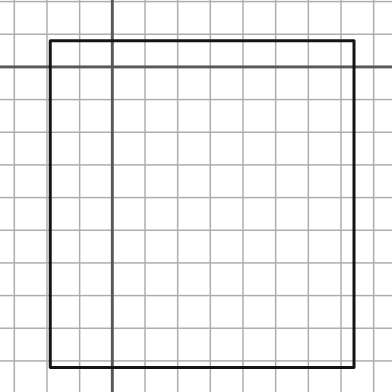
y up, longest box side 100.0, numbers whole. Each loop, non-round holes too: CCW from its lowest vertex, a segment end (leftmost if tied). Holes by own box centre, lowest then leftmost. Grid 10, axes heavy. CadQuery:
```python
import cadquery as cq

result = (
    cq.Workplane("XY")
    .moveTo(-19.0, -92.0)
    .lineTo(74.0, -92.0)
    .lineTo(74.0, 8.0)
    .lineTo(-19.0, 8.0)
    .close()
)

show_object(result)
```